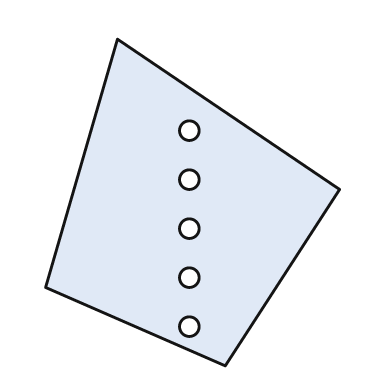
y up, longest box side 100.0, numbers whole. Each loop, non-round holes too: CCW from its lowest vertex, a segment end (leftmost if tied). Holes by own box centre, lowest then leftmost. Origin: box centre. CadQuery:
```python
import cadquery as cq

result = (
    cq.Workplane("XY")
    .moveTo(10.0, -50.0)
    .lineTo(45.0, 4.0)
    .lineTo(-23.0, 50.0)
    .lineTo(-45.0, -26.0)
    .close()
    .moveTo(-1.0, -38.0)
    .circle(3.0)
    .moveTo(-1.0, -23.0)
    .circle(3.0)
    .moveTo(-1.0, -8.0)
    .circle(3.0)
    .moveTo(-1.0, 7.0)
    .circle(3.0)
    .moveTo(-1.0, 22.0)
    .circle(3.0)
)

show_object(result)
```